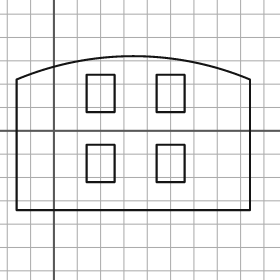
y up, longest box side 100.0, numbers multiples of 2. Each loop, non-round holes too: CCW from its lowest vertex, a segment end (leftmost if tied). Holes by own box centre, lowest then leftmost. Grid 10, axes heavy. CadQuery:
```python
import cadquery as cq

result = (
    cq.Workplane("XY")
    .moveTo(-16.0, -34.0)
    .lineTo(84.0, -34.0)
    .lineTo(84.0, 22.0)
    .threePointArc((34.0, 32.0), (-16.0, 22.0))
    .close()
    .moveTo(14.0, -22.0)
    .lineTo(26.0, -22.0)
    .lineTo(26.0, -6.0)
    .lineTo(14.0, -6.0)
    .close()
    .moveTo(44.0, -22.0)
    .lineTo(56.0, -22.0)
    .lineTo(56.0, -6.0)
    .lineTo(44.0, -6.0)
    .close()
    .moveTo(14.0, 8.0)
    .lineTo(26.0, 8.0)
    .lineTo(26.0, 24.0)
    .lineTo(14.0, 24.0)
    .close()
    .moveTo(44.0, 8.0)
    .lineTo(56.0, 8.0)
    .lineTo(56.0, 24.0)
    .lineTo(44.0, 24.0)
    .close()
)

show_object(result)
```